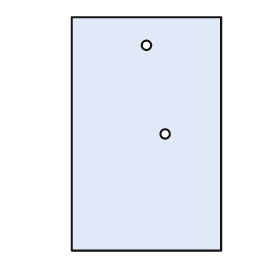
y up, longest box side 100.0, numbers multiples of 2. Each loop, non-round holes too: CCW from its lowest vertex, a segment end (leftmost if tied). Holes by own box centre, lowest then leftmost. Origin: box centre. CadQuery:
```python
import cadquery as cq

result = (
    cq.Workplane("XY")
    .moveTo(-32.0, -50.0)
    .lineTo(32.0, -50.0)
    .lineTo(32.0, 50.0)
    .lineTo(-32.0, 50.0)
    .close()
    .moveTo(8.0, 0.0)
    .circle(2.0)
    .moveTo(0.0, 38.0)
    .circle(2.0)
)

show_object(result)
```